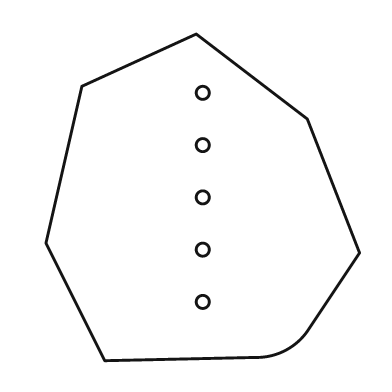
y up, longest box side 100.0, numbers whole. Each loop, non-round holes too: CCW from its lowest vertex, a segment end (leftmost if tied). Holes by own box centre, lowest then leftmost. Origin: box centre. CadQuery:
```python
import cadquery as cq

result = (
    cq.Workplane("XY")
    .moveTo(-30.0, -50.0)
    .lineTo(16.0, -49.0)
    .threePointArc((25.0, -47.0), (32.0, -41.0))
    .lineTo(48.0, -17.0)
    .lineTo(32.0, 24.0)
    .lineTo(-2.0, 50.0)
    .lineTo(-37.0, 34.0)
    .lineTo(-48.0, -14.0)
    .close()
    .moveTo(0.0, -32.0)
    .circle(2.0)
    .moveTo(0.0, -16.0)
    .circle(2.0)
    .moveTo(0.0, 0.0)
    .circle(2.0)
    .moveTo(0.0, 16.0)
    .circle(2.0)
    .moveTo(0.0, 32.0)
    .circle(2.0)
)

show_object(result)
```